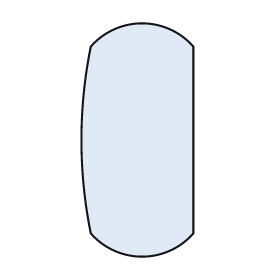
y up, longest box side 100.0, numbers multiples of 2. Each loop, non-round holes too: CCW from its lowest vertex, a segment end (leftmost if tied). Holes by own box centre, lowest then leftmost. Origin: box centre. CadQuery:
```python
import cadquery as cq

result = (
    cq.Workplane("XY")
    .moveTo(-20.0, -40.0)
    .threePointArc((2.0, -50.0), (24.0, -40.0))
    .lineTo(24.0, 40.0)
    .threePointArc((2.0, 50.0), (-20.0, 40.0))
    .threePointArc((-24.0, 0.0), (-20.0, -40.0))
    .close()
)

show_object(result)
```